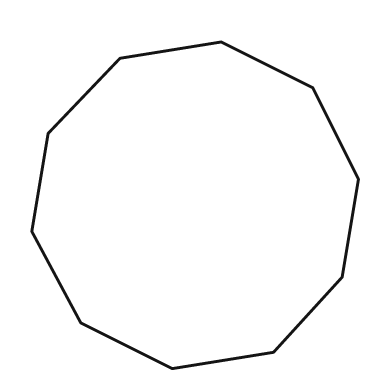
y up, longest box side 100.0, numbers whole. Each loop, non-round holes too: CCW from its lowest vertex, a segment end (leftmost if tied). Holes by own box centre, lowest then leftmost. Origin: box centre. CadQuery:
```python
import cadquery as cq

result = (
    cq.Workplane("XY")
    .moveTo(-7.0, -50.0)
    .lineTo(24.0, -45.0)
    .lineTo(45.0, -22.0)
    .lineTo(50.0, 8.0)
    .lineTo(36.0, 36.0)
    .lineTo(8.0, 50.0)
    .lineTo(-23.0, 45.0)
    .lineTo(-45.0, 22.0)
    .lineTo(-50.0, -8.0)
    .lineTo(-35.0, -36.0)
    .close()
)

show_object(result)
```